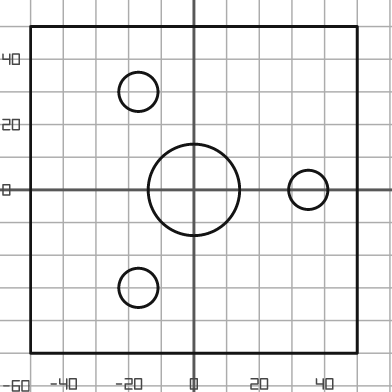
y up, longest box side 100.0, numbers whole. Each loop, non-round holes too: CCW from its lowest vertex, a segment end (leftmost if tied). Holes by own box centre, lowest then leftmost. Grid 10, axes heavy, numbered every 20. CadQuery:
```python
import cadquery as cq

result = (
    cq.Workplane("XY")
    .moveTo(-50.0, -50.0)
    .lineTo(50.0, -50.0)
    .lineTo(50.0, 50.0)
    .lineTo(-50.0, 50.0)
    .close()
    .moveTo(-17.0, -30.0)
    .circle(6.0)
    .moveTo(0.0, 0.0)
    .circle(14.0)
    .moveTo(35.0, 0.0)
    .circle(6.0)
    .moveTo(-17.0, 30.0)
    .circle(6.0)
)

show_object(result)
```